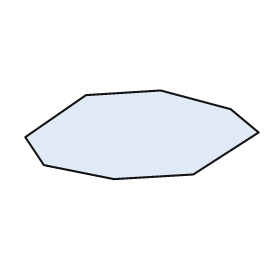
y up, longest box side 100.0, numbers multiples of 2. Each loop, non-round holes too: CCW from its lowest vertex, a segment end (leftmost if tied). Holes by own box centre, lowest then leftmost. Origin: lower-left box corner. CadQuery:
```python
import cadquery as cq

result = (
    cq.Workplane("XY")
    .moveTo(38.0, 0.0)
    .lineTo(72.0, 2.0)
    .lineTo(100.0, 20.0)
    .lineTo(88.0, 30.0)
    .lineTo(58.0, 38.0)
    .lineTo(26.0, 36.0)
    .lineTo(0.0, 18.0)
    .lineTo(8.0, 6.0)
    .close()
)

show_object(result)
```